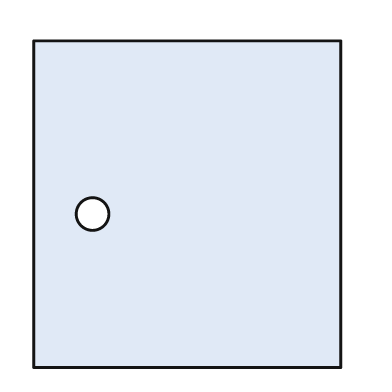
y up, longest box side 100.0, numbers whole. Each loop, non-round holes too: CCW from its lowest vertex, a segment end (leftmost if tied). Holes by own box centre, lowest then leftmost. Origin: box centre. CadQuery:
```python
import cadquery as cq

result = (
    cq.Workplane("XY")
    .moveTo(-47.0, -50.0)
    .lineTo(47.0, -50.0)
    .lineTo(47.0, 50.0)
    .lineTo(-47.0, 50.0)
    .close()
    .moveTo(-29.0, -3.0)
    .circle(5.0)
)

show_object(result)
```